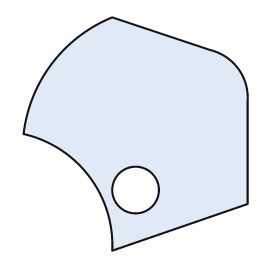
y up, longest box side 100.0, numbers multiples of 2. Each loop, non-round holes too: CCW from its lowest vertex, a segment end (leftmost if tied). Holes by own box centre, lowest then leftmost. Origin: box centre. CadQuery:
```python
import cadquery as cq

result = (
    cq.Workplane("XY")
    .moveTo(-10.0, -50.0)
    .lineTo(48.0, -30.0)
    .lineTo(48.0, 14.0)
    .threePointArc((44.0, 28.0), (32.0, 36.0))
    .lineTo(-10.0, 50.0)
    .threePointArc((-36.0, 30.0), (-48.0, 0.0))
    .threePointArc((-20.0, -18.0), (-10.0, -50.0))
    .close()
    .moveTo(0.0, -24.0)
    .circle(10.0)
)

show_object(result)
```